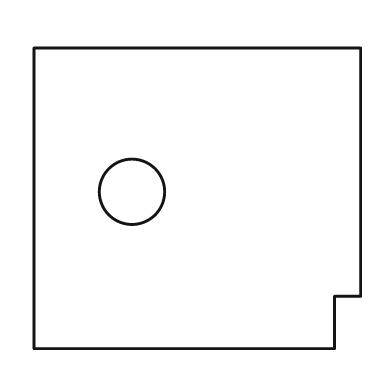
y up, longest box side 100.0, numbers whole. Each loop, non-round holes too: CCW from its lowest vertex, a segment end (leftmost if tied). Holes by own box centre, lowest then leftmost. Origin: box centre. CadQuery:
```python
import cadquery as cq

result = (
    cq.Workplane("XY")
    .moveTo(-50.0, -46.0)
    .lineTo(42.0, -46.0)
    .lineTo(42.0, -30.0)
    .lineTo(50.0, -30.0)
    .lineTo(50.0, 46.0)
    .lineTo(-50.0, 46.0)
    .close()
    .moveTo(-20.0, 2.0)
    .circle(10.0)
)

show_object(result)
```